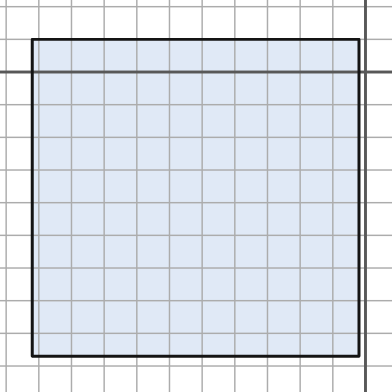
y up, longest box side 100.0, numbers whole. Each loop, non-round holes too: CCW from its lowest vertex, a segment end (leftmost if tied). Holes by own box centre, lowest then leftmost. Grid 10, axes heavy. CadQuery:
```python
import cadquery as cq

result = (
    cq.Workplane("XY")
    .moveTo(-102.0, -87.0)
    .lineTo(-2.0, -87.0)
    .lineTo(-2.0, 10.0)
    .lineTo(-102.0, 10.0)
    .close()
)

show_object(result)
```